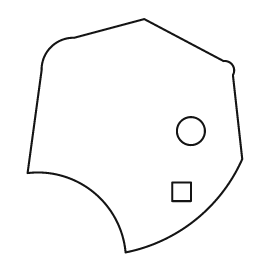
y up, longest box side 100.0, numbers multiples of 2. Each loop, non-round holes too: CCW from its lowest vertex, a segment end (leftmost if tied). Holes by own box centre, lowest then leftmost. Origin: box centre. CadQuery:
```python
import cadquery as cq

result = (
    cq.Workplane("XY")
    .moveTo(-4.0, -50.0)
    .threePointArc((26.0, -36.0), (46.0, -10.0))
    .lineTo(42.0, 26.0)
    .threePointArc((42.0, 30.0), (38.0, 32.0))
    .lineTo(4.0, 50.0)
    .lineTo(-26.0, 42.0)
    .threePointArc((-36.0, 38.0), (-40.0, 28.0))
    .lineTo(-46.0, -16.0)
    .threePointArc((-18.0, -24.0), (-4.0, -50.0))
    .close()
    .moveTo(16.0, -28.0)
    .lineTo(24.0, -28.0)
    .lineTo(24.0, -20.0)
    .lineTo(16.0, -20.0)
    .close()
    .moveTo(24.0, 2.0)
    .circle(6.0)
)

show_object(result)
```